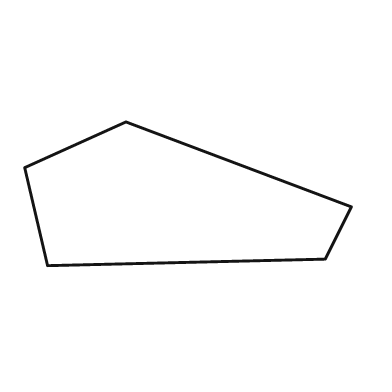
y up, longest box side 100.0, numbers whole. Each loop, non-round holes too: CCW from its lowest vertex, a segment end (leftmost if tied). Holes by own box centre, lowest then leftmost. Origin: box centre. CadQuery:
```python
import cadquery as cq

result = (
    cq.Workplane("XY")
    .moveTo(-43.0, -22.0)
    .lineTo(42.0, -20.0)
    .lineTo(50.0, -4.0)
    .lineTo(-19.0, 22.0)
    .lineTo(-50.0, 8.0)
    .close()
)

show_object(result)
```